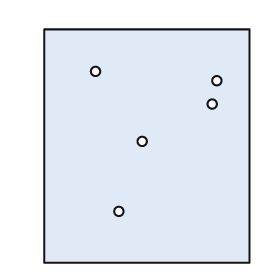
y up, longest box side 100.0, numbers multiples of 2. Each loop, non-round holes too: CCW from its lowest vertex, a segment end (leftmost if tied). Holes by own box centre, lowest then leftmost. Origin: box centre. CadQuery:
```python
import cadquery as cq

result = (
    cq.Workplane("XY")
    .moveTo(-44.0, -50.0)
    .lineTo(44.0, -50.0)
    .lineTo(44.0, 50.0)
    .lineTo(-44.0, 50.0)
    .close()
    .moveTo(-12.0, -28.0)
    .circle(2.0)
    .moveTo(-2.0, 2.0)
    .circle(2.0)
    .moveTo(28.0, 18.0)
    .circle(2.0)
    .moveTo(30.0, 28.0)
    .circle(2.0)
    .moveTo(-22.0, 32.0)
    .circle(2.0)
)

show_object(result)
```